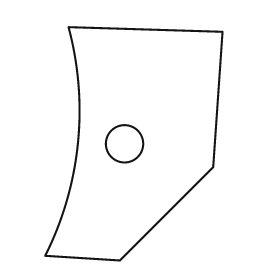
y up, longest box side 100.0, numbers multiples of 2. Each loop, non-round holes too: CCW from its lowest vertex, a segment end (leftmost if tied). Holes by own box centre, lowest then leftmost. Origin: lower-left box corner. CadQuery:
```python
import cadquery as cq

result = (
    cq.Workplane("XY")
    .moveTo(32.0, 0.0)
    .lineTo(72.0, 40.0)
    .lineTo(76.0, 98.0)
    .lineTo(10.0, 100.0)
    .threePointArc((14.0, 50.0), (0.0, 2.0))
    .close()
    .moveTo(34.0, 50.0)
    .circle(8.0)
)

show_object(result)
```